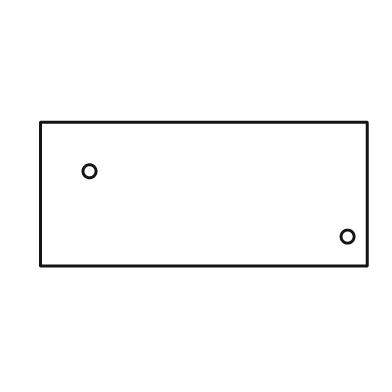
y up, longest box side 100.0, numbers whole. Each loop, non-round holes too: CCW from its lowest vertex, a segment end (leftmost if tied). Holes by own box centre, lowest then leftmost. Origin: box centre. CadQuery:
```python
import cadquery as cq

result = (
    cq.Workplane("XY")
    .moveTo(-50.0, -22.0)
    .lineTo(50.0, -22.0)
    .lineTo(50.0, 22.0)
    .lineTo(-50.0, 22.0)
    .close()
    .moveTo(44.0, -13.0)
    .circle(2.0)
    .moveTo(-35.0, 7.0)
    .circle(2.0)
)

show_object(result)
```